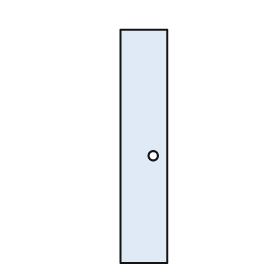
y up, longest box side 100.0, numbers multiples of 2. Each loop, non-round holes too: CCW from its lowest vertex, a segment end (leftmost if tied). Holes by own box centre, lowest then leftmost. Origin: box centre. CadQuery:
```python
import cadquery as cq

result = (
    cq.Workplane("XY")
    .moveTo(-10.0, -50.0)
    .lineTo(10.0, -50.0)
    .lineTo(10.0, 50.0)
    .lineTo(-10.0, 50.0)
    .close()
    .moveTo(4.0, -4.0)
    .circle(2.0)
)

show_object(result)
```